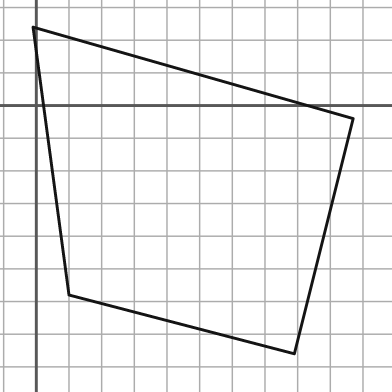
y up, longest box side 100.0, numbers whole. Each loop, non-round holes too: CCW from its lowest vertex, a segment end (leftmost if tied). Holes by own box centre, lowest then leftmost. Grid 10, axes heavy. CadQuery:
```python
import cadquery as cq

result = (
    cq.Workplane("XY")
    .moveTo(79.0, -76.0)
    .lineTo(97.0, -4.0)
    .lineTo(-1.0, 24.0)
    .lineTo(10.0, -58.0)
    .close()
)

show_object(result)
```